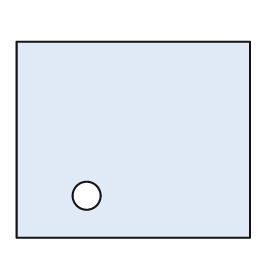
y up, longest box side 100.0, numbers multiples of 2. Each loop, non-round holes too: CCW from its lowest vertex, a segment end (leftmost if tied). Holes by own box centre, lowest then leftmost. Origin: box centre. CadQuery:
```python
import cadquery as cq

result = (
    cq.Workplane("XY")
    .moveTo(-50.0, -42.0)
    .lineTo(50.0, -42.0)
    .lineTo(50.0, 42.0)
    .lineTo(-50.0, 42.0)
    .close()
    .moveTo(-20.0, -24.0)
    .circle(6.0)
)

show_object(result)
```